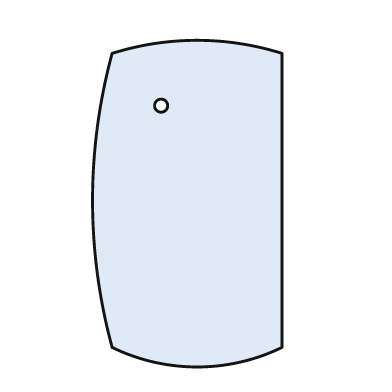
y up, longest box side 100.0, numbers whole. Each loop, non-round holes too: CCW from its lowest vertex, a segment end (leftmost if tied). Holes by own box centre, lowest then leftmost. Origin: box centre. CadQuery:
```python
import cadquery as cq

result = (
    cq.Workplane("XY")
    .moveTo(-23.0, -44.0)
    .threePointArc((3.0, -50.0), (29.0, -44.0))
    .lineTo(29.0, 46.0)
    .threePointArc((3.0, 50.0), (-23.0, 46.0))
    .threePointArc((-29.0, 1.0), (-23.0, -44.0))
    .close()
    .moveTo(-8.0, 30.0)
    .circle(2.0)
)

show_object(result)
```